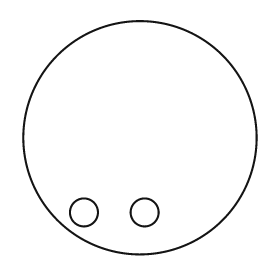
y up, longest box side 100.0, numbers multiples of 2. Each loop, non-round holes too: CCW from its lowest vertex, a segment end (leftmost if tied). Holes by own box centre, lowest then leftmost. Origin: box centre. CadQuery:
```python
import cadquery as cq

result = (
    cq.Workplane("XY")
    .moveTo(0.0, 0.0)
    .circle(50.0)
    .moveTo(-24.0, -32.0)
    .circle(6.0)
    .moveTo(2.0, -32.0)
    .circle(6.0)
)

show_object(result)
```